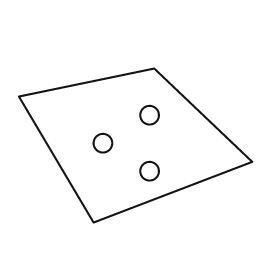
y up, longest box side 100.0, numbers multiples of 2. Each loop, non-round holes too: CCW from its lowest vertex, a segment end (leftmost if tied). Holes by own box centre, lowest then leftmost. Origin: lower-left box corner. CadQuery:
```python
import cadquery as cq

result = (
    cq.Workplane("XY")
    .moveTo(32.0, 0.0)
    .lineTo(100.0, 26.0)
    .lineTo(58.0, 66.0)
    .lineTo(0.0, 54.0)
    .close()
    .moveTo(56.0, 22.0)
    .circle(4.0)
    .moveTo(36.0, 34.0)
    .circle(4.0)
    .moveTo(56.0, 46.0)
    .circle(4.0)
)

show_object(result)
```